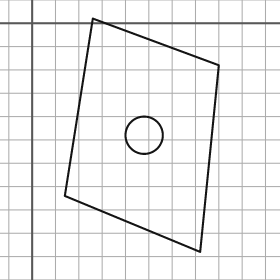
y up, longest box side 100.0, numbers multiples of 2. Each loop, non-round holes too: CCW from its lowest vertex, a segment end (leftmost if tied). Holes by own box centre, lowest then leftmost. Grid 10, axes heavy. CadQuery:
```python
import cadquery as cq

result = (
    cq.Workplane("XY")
    .moveTo(72.0, -98.0)
    .lineTo(80.0, -18.0)
    .lineTo(26.0, 2.0)
    .lineTo(14.0, -74.0)
    .close()
    .moveTo(48.0, -48.0)
    .circle(8.0)
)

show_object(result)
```